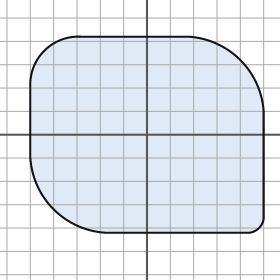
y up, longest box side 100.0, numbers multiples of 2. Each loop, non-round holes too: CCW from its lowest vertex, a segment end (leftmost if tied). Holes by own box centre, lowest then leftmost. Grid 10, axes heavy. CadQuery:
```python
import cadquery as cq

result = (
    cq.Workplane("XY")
    .moveTo(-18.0, -42.0)
    .lineTo(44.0, -42.0)
    .threePointArc((48.0, -40.0), (50.0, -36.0))
    .lineTo(50.0, 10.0)
    .threePointArc((40.0, 32.0), (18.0, 42.0))
    .lineTo(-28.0, 42.0)
    .threePointArc((-44.0, 36.0), (-50.0, 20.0))
    .lineTo(-50.0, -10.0)
    .threePointArc((-40.0, -32.0), (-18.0, -42.0))
    .close()
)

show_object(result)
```